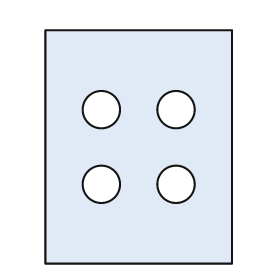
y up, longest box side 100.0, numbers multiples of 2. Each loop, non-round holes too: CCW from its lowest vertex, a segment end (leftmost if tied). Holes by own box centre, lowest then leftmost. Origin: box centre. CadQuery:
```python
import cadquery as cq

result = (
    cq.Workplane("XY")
    .moveTo(-40.0, -50.0)
    .lineTo(40.0, -50.0)
    .lineTo(40.0, 50.0)
    .lineTo(-40.0, 50.0)
    .close()
    .moveTo(-16.0, -16.0)
    .circle(8.0)
    .moveTo(16.0, -16.0)
    .circle(8.0)
    .moveTo(-16.0, 16.0)
    .circle(8.0)
    .moveTo(16.0, 16.0)
    .circle(8.0)
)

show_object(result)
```